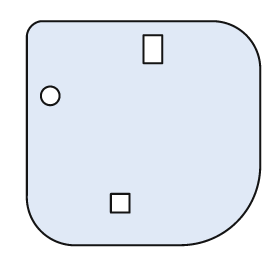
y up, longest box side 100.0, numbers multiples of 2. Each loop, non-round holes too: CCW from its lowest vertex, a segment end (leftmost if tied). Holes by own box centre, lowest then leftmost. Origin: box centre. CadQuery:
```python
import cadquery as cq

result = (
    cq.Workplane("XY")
    .moveTo(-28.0, -48.0)
    .lineTo(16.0, -48.0)
    .threePointArc((40.0, -38.0), (50.0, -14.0))
    .lineTo(50.0, 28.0)
    .threePointArc((44.0, 42.0), (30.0, 48.0))
    .lineTo(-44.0, 48.0)
    .threePointArc((-48.0, 46.0), (-50.0, 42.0))
    .lineTo(-50.0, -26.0)
    .threePointArc((-44.0, -42.0), (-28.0, -48.0))
    .close()
    .moveTo(-14.0, -34.0)
    .lineTo(-6.0, -34.0)
    .lineTo(-6.0, -26.0)
    .lineTo(-14.0, -26.0)
    .close()
    .moveTo(-40.0, 16.0)
    .circle(4.0)
    .moveTo(0.0, 30.0)
    .lineTo(8.0, 30.0)
    .lineTo(8.0, 42.0)
    .lineTo(0.0, 42.0)
    .close()
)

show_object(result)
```